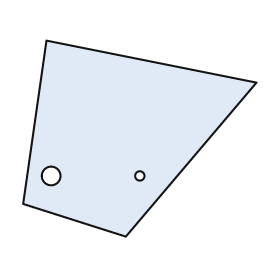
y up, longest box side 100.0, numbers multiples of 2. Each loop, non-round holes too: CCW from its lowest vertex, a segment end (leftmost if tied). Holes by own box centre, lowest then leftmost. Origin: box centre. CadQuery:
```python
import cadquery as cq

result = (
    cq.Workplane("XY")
    .moveTo(-6.0, -42.0)
    .lineTo(50.0, 24.0)
    .lineTo(-40.0, 42.0)
    .lineTo(-50.0, -28.0)
    .close()
    .moveTo(-38.0, -16.0)
    .circle(4.0)
    .moveTo(0.0, -16.0)
    .circle(2.0)
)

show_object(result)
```